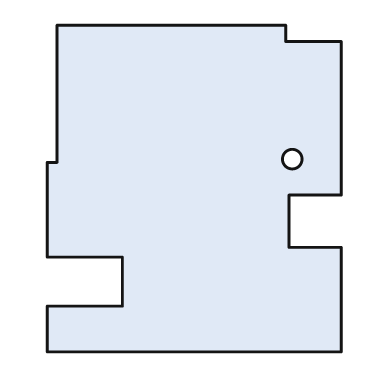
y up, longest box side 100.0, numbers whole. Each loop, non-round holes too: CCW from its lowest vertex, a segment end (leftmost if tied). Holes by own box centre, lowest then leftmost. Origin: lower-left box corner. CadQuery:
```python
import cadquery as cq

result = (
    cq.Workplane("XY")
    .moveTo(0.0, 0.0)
    .lineTo(90.0, 0.0)
    .lineTo(90.0, 32.0)
    .lineTo(74.0, 32.0)
    .lineTo(74.0, 48.0)
    .lineTo(90.0, 48.0)
    .lineTo(90.0, 95.0)
    .lineTo(73.0, 95.0)
    .lineTo(73.0, 100.0)
    .lineTo(3.0, 100.0)
    .lineTo(3.0, 58.0)
    .lineTo(0.0, 58.0)
    .lineTo(0.0, 29.0)
    .lineTo(23.0, 29.0)
    .lineTo(23.0, 14.0)
    .lineTo(0.0, 14.0)
    .close()
    .moveTo(75.0, 59.0)
    .circle(3.0)
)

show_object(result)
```